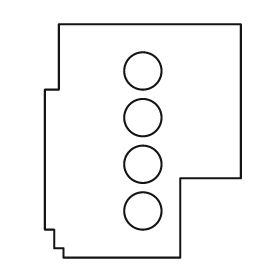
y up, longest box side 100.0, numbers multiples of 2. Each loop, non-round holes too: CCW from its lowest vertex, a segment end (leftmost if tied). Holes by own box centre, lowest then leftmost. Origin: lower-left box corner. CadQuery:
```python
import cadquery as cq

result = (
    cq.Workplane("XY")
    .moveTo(8.0, 0.0)
    .lineTo(58.0, 0.0)
    .lineTo(58.0, 34.0)
    .lineTo(84.0, 34.0)
    .lineTo(84.0, 100.0)
    .lineTo(6.0, 100.0)
    .lineTo(6.0, 72.0)
    .lineTo(0.0, 72.0)
    .lineTo(0.0, 12.0)
    .lineTo(4.0, 12.0)
    .lineTo(4.0, 4.0)
    .lineTo(8.0, 4.0)
    .close()
    .moveTo(42.0, 20.0)
    .circle(8.0)
    .moveTo(42.0, 40.0)
    .circle(8.0)
    .moveTo(42.0, 60.0)
    .circle(8.0)
    .moveTo(42.0, 80.0)
    .circle(8.0)
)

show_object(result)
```